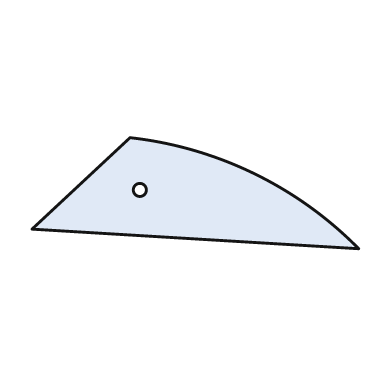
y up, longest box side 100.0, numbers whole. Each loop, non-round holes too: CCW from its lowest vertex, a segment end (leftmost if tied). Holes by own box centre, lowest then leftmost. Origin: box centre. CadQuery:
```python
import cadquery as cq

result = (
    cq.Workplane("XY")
    .moveTo(50.0, -17.0)
    .threePointArc((18.0, 6.0), (-20.0, 17.0))
    .lineTo(-50.0, -11.0)
    .close()
    .moveTo(-17.0, 1.0)
    .circle(2.0)
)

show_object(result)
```